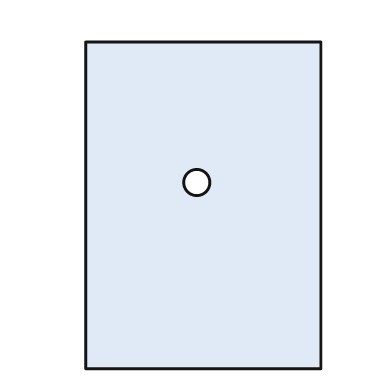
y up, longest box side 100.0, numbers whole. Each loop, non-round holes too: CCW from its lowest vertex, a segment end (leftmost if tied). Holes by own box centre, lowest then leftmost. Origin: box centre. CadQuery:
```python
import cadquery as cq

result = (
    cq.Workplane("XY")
    .moveTo(-36.0, -50.0)
    .lineTo(36.0, -50.0)
    .lineTo(36.0, 50.0)
    .lineTo(-36.0, 50.0)
    .close()
    .moveTo(-2.0, 7.0)
    .circle(4.0)
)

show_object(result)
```